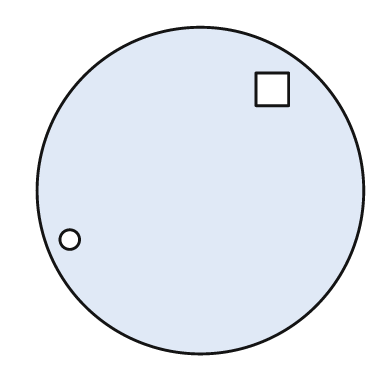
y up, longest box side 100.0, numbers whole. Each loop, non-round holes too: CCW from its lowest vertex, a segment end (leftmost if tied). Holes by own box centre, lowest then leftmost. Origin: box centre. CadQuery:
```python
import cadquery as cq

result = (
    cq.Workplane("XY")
    .moveTo(0.0, 0.0)
    .circle(50.0)
    .moveTo(-40.0, -15.0)
    .circle(3.0)
    .moveTo(17.0, 26.0)
    .lineTo(27.0, 26.0)
    .lineTo(27.0, 36.0)
    .lineTo(17.0, 36.0)
    .close()
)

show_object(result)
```